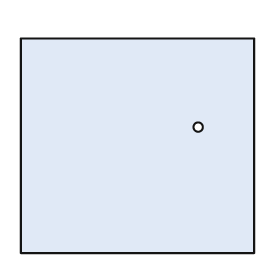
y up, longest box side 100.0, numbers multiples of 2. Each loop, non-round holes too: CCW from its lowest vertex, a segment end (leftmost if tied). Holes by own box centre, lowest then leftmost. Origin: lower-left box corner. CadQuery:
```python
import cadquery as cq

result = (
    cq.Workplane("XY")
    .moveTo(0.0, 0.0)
    .lineTo(100.0, 0.0)
    .lineTo(100.0, 92.0)
    .lineTo(0.0, 92.0)
    .close()
    .moveTo(76.0, 54.0)
    .circle(2.0)
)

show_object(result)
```